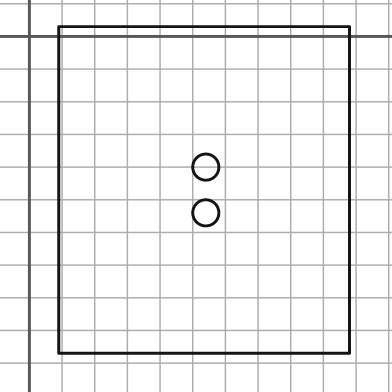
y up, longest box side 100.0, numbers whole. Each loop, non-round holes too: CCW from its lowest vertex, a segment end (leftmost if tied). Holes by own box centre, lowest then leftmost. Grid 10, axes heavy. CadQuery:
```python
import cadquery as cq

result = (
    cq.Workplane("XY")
    .moveTo(9.0, -97.0)
    .lineTo(98.0, -97.0)
    .lineTo(98.0, 3.0)
    .lineTo(9.0, 3.0)
    .close()
    .moveTo(54.0, -54.0)
    .circle(4.0)
    .moveTo(54.0, -40.0)
    .circle(4.0)
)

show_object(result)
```